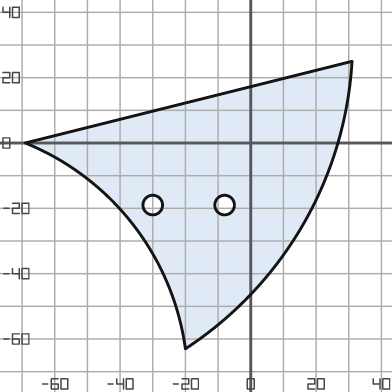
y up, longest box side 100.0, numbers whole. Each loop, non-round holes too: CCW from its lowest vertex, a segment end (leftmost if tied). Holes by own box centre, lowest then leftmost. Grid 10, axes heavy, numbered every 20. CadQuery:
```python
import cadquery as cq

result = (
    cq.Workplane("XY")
    .moveTo(-20.0, -63.0)
    .threePointArc((16.0, -25.0), (31.0, 25.0))
    .lineTo(-69.0, 0.0)
    .threePointArc((-36.0, -25.0), (-20.0, -63.0))
    .close()
    .moveTo(-30.0, -19.0)
    .circle(3.0)
    .moveTo(-8.0, -19.0)
    .circle(3.0)
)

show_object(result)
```